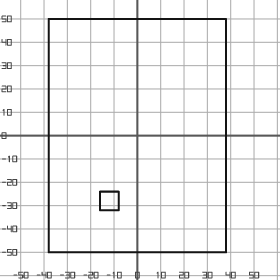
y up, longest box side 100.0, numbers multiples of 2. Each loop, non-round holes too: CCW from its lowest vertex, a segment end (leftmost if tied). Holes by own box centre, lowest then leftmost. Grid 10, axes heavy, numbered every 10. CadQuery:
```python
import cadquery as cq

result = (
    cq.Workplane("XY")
    .moveTo(-38.0, -50.0)
    .lineTo(38.0, -50.0)
    .lineTo(38.0, 50.0)
    .lineTo(-38.0, 50.0)
    .close()
    .moveTo(-16.0, -32.0)
    .lineTo(-8.0, -32.0)
    .lineTo(-8.0, -24.0)
    .lineTo(-16.0, -24.0)
    .close()
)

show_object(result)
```